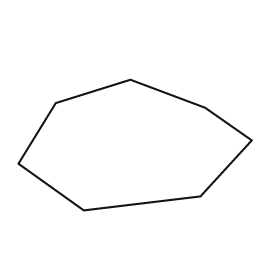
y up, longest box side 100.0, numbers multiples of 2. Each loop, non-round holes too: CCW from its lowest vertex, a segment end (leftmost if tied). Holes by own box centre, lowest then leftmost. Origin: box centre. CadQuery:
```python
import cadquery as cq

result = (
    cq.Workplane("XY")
    .moveTo(-22.0, -28.0)
    .lineTo(28.0, -22.0)
    .lineTo(50.0, 2.0)
    .lineTo(30.0, 16.0)
    .lineTo(-2.0, 28.0)
    .lineTo(-34.0, 18.0)
    .lineTo(-50.0, -8.0)
    .close()
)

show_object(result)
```